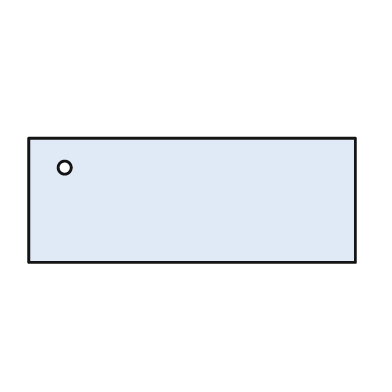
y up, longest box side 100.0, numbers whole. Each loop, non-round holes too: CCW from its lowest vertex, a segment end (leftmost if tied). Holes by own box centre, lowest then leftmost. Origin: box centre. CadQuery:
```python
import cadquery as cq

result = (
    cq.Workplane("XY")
    .moveTo(-50.0, -19.0)
    .lineTo(50.0, -19.0)
    .lineTo(50.0, 19.0)
    .lineTo(-50.0, 19.0)
    .close()
    .moveTo(-39.0, 10.0)
    .circle(2.0)
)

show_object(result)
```